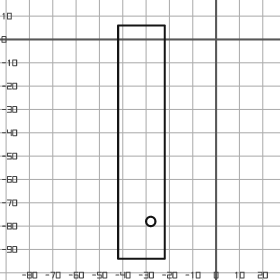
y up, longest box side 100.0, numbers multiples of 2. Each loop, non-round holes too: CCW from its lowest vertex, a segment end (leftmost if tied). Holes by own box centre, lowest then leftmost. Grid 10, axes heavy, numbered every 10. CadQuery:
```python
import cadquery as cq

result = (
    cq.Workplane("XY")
    .moveTo(-42.0, -94.0)
    .lineTo(-22.0, -94.0)
    .lineTo(-22.0, 6.0)
    .lineTo(-42.0, 6.0)
    .close()
    .moveTo(-28.0, -78.0)
    .circle(2.0)
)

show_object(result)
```